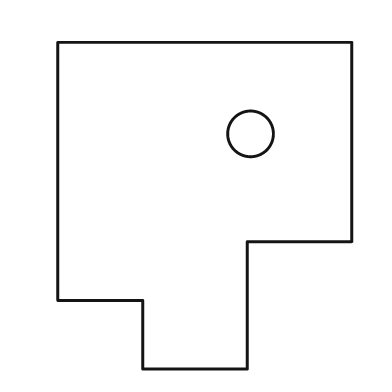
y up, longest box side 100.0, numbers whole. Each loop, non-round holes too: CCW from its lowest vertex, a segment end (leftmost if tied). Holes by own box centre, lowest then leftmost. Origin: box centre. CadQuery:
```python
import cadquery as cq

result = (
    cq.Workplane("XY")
    .moveTo(-19.0, -50.0)
    .lineTo(13.0, -50.0)
    .lineTo(13.0, -11.0)
    .lineTo(45.0, -11.0)
    .lineTo(45.0, 50.0)
    .lineTo(-45.0, 50.0)
    .lineTo(-45.0, -29.0)
    .lineTo(-19.0, -29.0)
    .close()
    .moveTo(14.0, 22.0)
    .circle(7.0)
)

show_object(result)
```